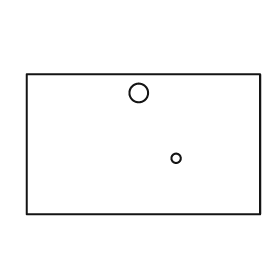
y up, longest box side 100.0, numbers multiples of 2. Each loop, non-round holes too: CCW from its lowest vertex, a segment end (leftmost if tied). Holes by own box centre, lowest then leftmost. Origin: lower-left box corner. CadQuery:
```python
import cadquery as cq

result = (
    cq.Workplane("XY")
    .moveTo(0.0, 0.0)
    .lineTo(100.0, 0.0)
    .lineTo(100.0, 60.0)
    .lineTo(0.0, 60.0)
    .close()
    .moveTo(64.0, 24.0)
    .circle(2.0)
    .moveTo(48.0, 52.0)
    .circle(4.0)
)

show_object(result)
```